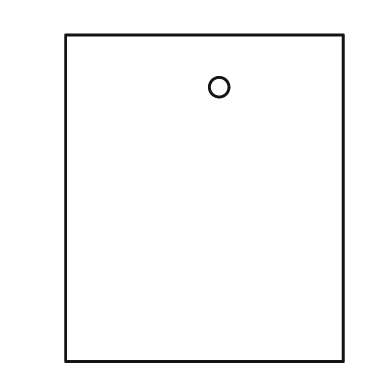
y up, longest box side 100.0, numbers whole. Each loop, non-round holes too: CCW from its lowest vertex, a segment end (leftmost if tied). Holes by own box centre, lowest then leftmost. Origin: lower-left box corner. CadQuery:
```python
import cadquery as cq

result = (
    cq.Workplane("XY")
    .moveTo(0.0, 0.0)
    .lineTo(85.0, 0.0)
    .lineTo(85.0, 100.0)
    .lineTo(0.0, 100.0)
    .close()
    .moveTo(47.0, 84.0)
    .circle(3.0)
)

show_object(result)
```